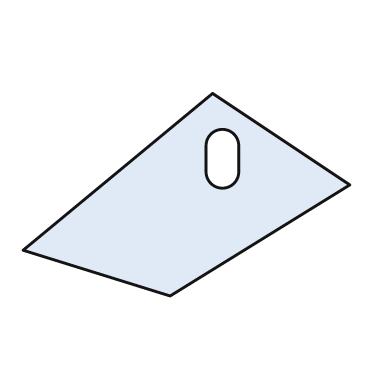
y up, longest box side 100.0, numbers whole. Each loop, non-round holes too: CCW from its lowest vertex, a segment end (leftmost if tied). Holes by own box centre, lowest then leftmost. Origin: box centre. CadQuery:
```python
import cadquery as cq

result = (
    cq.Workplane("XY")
    .moveTo(-5.0, -31.0)
    .lineTo(50.0, 3.0)
    .lineTo(8.0, 31.0)
    .lineTo(-50.0, -17.0)
    .close()
    .moveTo(6.0, 7.0)
    .threePointArc((11.0, 2.0), (16.0, 7.0))
    .lineTo(16.0, 15.0)
    .threePointArc((11.0, 20.0), (6.0, 15.0))
    .close()
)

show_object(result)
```